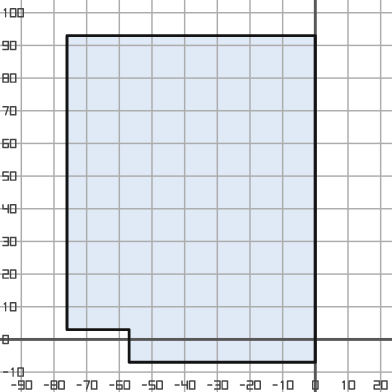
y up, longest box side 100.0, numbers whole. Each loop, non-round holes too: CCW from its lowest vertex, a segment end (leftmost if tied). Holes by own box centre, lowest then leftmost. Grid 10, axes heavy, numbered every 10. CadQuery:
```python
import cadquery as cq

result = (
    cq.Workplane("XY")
    .moveTo(-57.0, -7.0)
    .lineTo(0.0, -7.0)
    .lineTo(0.0, 93.0)
    .lineTo(-76.0, 93.0)
    .lineTo(-76.0, 3.0)
    .lineTo(-57.0, 3.0)
    .close()
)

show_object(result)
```